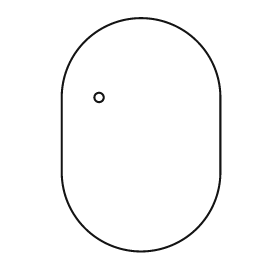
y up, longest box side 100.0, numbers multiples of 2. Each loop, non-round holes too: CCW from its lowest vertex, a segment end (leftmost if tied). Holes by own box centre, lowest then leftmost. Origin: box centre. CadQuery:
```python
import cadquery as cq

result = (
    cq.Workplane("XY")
    .moveTo(-34.0, -16.0)
    .threePointArc((0.0, -50.0), (34.0, -16.0))
    .lineTo(34.0, 16.0)
    .threePointArc((0.0, 50.0), (-34.0, 16.0))
    .close()
    .moveTo(-18.0, 16.0)
    .circle(2.0)
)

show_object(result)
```